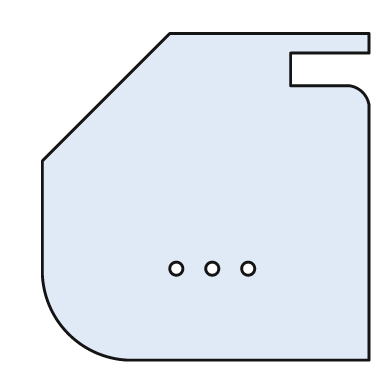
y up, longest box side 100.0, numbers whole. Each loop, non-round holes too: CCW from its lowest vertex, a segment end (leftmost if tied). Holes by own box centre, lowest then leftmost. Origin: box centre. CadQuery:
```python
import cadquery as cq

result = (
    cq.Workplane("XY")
    .moveTo(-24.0, -50.0)
    .lineTo(50.0, -50.0)
    .lineTo(50.0, 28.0)
    .threePointArc((48.0, 32.0), (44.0, 34.0))
    .lineTo(26.0, 34.0)
    .lineTo(26.0, 44.0)
    .lineTo(50.0, 44.0)
    .lineTo(50.0, 50.0)
    .lineTo(-11.0, 50.0)
    .lineTo(-50.0, 11.0)
    .lineTo(-50.0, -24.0)
    .threePointArc((-42.0, -42.0), (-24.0, -50.0))
    .close()
    .moveTo(-9.0, -22.0)
    .circle(2.0)
    .moveTo(2.0, -22.0)
    .circle(2.0)
    .moveTo(13.0, -22.0)
    .circle(2.0)
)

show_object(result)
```